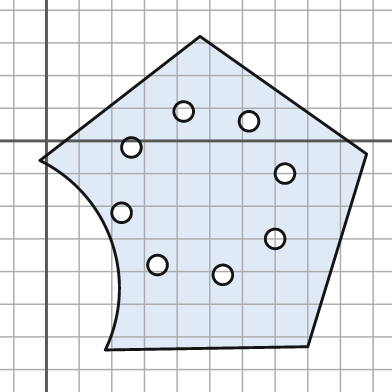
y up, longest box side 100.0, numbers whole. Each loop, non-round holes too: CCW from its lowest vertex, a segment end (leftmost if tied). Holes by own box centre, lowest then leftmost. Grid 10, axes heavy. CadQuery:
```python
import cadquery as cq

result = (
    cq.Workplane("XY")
    .moveTo(18.0, -64.0)
    .lineTo(80.0, -63.0)
    .lineTo(98.0, -4.0)
    .lineTo(47.0, 32.0)
    .lineTo(-2.0, -6.0)
    .threePointArc((20.0, -31.0), (18.0, -64.0))
    .close()
    .moveTo(54.0, -41.0)
    .circle(3.0)
    .moveTo(34.0, -38.0)
    .circle(3.0)
    .moveTo(70.0, -30.0)
    .circle(3.0)
    .moveTo(23.0, -22.0)
    .circle(3.0)
    .moveTo(73.0, -10.0)
    .circle(3.0)
    .moveTo(26.0, -2.0)
    .circle(3.0)
    .moveTo(62.0, 6.0)
    .circle(3.0)
    .moveTo(42.0, 9.0)
    .circle(3.0)
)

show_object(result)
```